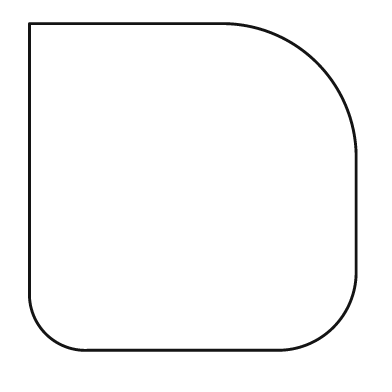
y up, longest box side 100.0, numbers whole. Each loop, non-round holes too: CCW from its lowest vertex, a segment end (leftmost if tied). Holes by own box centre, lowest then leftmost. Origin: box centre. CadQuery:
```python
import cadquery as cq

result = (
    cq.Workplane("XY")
    .moveTo(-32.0, -50.0)
    .lineTo(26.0, -50.0)
    .threePointArc((43.0, -43.0), (50.0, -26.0))
    .lineTo(50.0, 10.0)
    .threePointArc((38.0, 38.0), (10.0, 50.0))
    .lineTo(-50.0, 50.0)
    .lineTo(-50.0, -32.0)
    .threePointArc((-45.0, -45.0), (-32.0, -50.0))
    .close()
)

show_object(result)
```